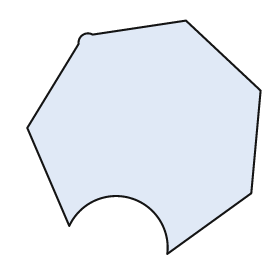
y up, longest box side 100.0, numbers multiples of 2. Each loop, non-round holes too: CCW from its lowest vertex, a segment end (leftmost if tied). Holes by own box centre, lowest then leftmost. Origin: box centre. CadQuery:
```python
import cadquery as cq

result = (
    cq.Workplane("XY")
    .moveTo(10.0, -50.0)
    .lineTo(46.0, -24.0)
    .lineTo(50.0, 20.0)
    .lineTo(18.0, 50.0)
    .lineTo(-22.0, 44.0)
    .threePointArc((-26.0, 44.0), (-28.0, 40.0))
    .lineTo(-50.0, 4.0)
    .lineTo(-32.0, -38.0)
    .threePointArc((-6.0, -26.0), (10.0, -50.0))
    .close()
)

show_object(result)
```